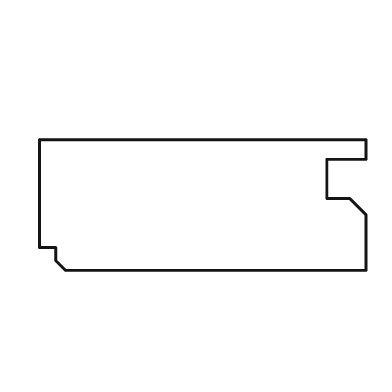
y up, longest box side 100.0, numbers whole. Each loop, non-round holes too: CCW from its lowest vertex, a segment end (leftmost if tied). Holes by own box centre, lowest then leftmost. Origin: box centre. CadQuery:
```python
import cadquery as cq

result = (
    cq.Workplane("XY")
    .moveTo(-42.0, -20.0)
    .lineTo(50.0, -20.0)
    .lineTo(50.0, -3.0)
    .lineTo(45.0, 2.0)
    .lineTo(38.0, 2.0)
    .lineTo(38.0, 14.0)
    .lineTo(50.0, 14.0)
    .lineTo(50.0, 20.0)
    .lineTo(-50.0, 20.0)
    .lineTo(-50.0, -13.0)
    .lineTo(-45.0, -13.0)
    .lineTo(-45.0, -17.0)
    .close()
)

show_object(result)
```